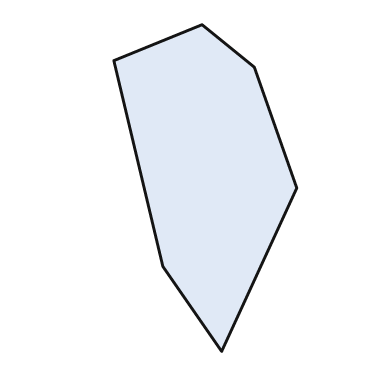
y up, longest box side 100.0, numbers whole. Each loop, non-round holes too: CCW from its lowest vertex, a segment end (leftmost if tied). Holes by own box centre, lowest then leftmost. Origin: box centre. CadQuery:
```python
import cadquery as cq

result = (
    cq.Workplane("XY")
    .moveTo(5.0, -50.0)
    .lineTo(28.0, 0.0)
    .lineTo(15.0, 37.0)
    .lineTo(-1.0, 50.0)
    .lineTo(-28.0, 39.0)
    .lineTo(-13.0, -24.0)
    .close()
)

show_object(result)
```